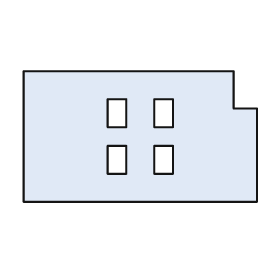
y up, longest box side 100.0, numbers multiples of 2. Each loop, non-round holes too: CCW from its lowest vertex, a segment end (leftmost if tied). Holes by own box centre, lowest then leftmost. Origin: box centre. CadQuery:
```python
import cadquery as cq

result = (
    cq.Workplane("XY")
    .moveTo(-50.0, -28.0)
    .lineTo(50.0, -28.0)
    .lineTo(50.0, 12.0)
    .lineTo(40.0, 12.0)
    .lineTo(40.0, 28.0)
    .lineTo(-50.0, 28.0)
    .close()
    .moveTo(-14.0, -16.0)
    .lineTo(-6.0, -16.0)
    .lineTo(-6.0, -4.0)
    .lineTo(-14.0, -4.0)
    .close()
    .moveTo(6.0, -16.0)
    .lineTo(14.0, -16.0)
    .lineTo(14.0, -4.0)
    .lineTo(6.0, -4.0)
    .close()
    .moveTo(-14.0, 4.0)
    .lineTo(-6.0, 4.0)
    .lineTo(-6.0, 16.0)
    .lineTo(-14.0, 16.0)
    .close()
    .moveTo(6.0, 4.0)
    .lineTo(14.0, 4.0)
    .lineTo(14.0, 16.0)
    .lineTo(6.0, 16.0)
    .close()
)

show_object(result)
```